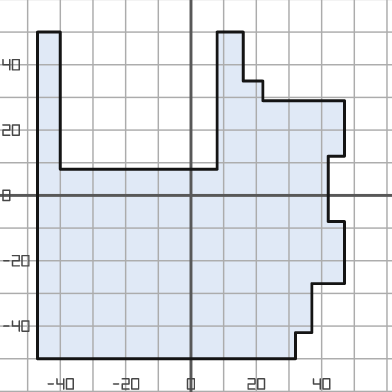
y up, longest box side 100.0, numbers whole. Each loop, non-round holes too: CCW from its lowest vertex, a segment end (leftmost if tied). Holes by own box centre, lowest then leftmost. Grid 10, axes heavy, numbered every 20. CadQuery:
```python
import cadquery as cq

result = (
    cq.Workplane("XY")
    .moveTo(-47.0, -50.0)
    .lineTo(32.0, -50.0)
    .lineTo(32.0, -42.0)
    .lineTo(37.0, -42.0)
    .lineTo(37.0, -27.0)
    .lineTo(47.0, -27.0)
    .lineTo(47.0, -8.0)
    .lineTo(42.0, -8.0)
    .lineTo(42.0, 12.0)
    .lineTo(47.0, 12.0)
    .lineTo(47.0, 29.0)
    .lineTo(22.0, 29.0)
    .lineTo(22.0, 35.0)
    .lineTo(16.0, 35.0)
    .lineTo(16.0, 50.0)
    .lineTo(8.0, 50.0)
    .lineTo(8.0, 8.0)
    .lineTo(-40.0, 8.0)
    .lineTo(-40.0, 50.0)
    .lineTo(-47.0, 50.0)
    .close()
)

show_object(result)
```